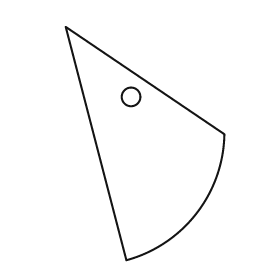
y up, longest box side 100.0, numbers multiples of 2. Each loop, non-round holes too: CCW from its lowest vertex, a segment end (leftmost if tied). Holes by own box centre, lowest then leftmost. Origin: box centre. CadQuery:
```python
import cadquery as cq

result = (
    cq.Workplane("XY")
    .moveTo(-8.0, -50.0)
    .threePointArc((22.0, -30.0), (34.0, 4.0))
    .lineTo(-34.0, 50.0)
    .close()
    .moveTo(-6.0, 20.0)
    .circle(4.0)
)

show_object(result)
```